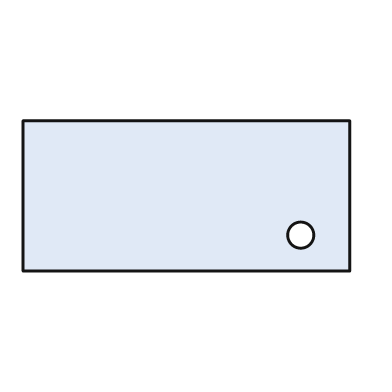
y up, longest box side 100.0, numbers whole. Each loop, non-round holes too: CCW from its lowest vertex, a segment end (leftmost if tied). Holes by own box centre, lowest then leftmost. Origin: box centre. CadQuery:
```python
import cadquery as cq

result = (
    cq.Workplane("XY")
    .moveTo(-50.0, -23.0)
    .lineTo(50.0, -23.0)
    .lineTo(50.0, 23.0)
    .lineTo(-50.0, 23.0)
    .close()
    .moveTo(35.0, -12.0)
    .circle(4.0)
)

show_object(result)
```